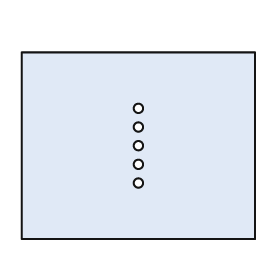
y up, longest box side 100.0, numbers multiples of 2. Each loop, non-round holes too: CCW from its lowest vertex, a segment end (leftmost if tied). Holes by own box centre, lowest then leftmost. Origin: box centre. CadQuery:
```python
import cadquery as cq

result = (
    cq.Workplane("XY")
    .moveTo(-50.0, -40.0)
    .lineTo(50.0, -40.0)
    .lineTo(50.0, 40.0)
    .lineTo(-50.0, 40.0)
    .close()
    .moveTo(0.0, -16.0)
    .circle(2.0)
    .moveTo(0.0, -8.0)
    .circle(2.0)
    .moveTo(0.0, 0.0)
    .circle(2.0)
    .moveTo(0.0, 8.0)
    .circle(2.0)
    .moveTo(0.0, 16.0)
    .circle(2.0)
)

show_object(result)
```